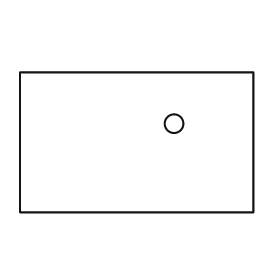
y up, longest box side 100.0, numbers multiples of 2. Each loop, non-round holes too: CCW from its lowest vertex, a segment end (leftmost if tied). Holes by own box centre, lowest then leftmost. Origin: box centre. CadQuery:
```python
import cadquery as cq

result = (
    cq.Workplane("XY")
    .moveTo(-50.0, -30.0)
    .lineTo(50.0, -30.0)
    .lineTo(50.0, 30.0)
    .lineTo(-50.0, 30.0)
    .close()
    .moveTo(16.0, 8.0)
    .circle(4.0)
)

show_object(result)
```